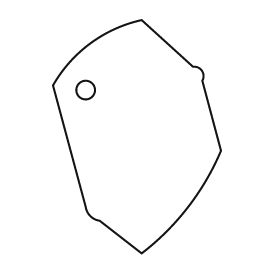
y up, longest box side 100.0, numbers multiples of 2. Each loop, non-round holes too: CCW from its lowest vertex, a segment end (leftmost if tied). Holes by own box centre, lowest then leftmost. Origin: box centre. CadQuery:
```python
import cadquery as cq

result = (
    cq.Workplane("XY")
    .moveTo(2.0, -50.0)
    .threePointArc((22.0, -30.0), (36.0, -6.0))
    .lineTo(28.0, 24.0)
    .threePointArc((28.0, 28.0), (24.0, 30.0))
    .lineTo(2.0, 50.0)
    .threePointArc((-20.0, 40.0), (-36.0, 22.0))
    .lineTo(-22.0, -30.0)
    .threePointArc((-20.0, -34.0), (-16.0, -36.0))
    .close()
    .moveTo(-22.0, 20.0)
    .circle(4.0)
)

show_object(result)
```